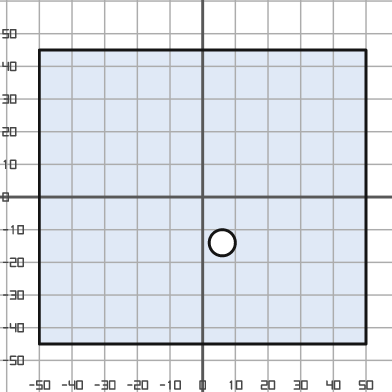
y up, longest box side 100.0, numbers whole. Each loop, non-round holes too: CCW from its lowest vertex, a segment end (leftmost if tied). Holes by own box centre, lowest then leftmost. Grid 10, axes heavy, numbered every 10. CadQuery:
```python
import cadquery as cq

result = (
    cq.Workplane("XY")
    .moveTo(-50.0, -45.0)
    .lineTo(50.0, -45.0)
    .lineTo(50.0, 45.0)
    .lineTo(-50.0, 45.0)
    .close()
    .moveTo(6.0, -14.0)
    .circle(4.0)
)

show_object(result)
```